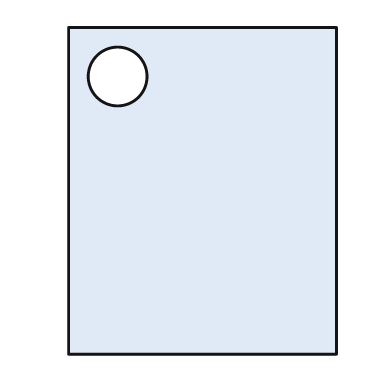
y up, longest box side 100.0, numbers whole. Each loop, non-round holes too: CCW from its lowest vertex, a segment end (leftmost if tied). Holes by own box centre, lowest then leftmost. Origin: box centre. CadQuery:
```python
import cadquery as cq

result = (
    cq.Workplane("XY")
    .moveTo(-41.0, -50.0)
    .lineTo(41.0, -50.0)
    .lineTo(41.0, 50.0)
    .lineTo(-41.0, 50.0)
    .close()
    .moveTo(-26.0, 35.0)
    .circle(9.0)
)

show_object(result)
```